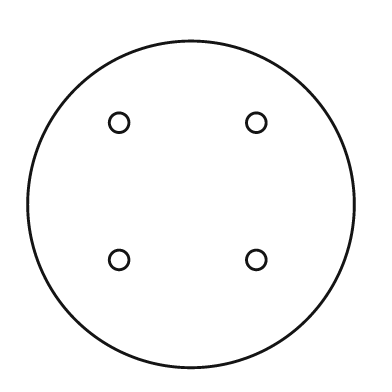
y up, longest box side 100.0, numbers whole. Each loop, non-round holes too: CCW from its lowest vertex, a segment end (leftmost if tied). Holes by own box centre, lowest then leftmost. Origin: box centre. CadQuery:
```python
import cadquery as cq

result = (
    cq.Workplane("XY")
    .moveTo(0.0, 0.0)
    .circle(50.0)
    .moveTo(-22.0, -17.0)
    .circle(3.0)
    .moveTo(20.0, -17.0)
    .circle(3.0)
    .moveTo(-22.0, 25.0)
    .circle(3.0)
    .moveTo(20.0, 25.0)
    .circle(3.0)
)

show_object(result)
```